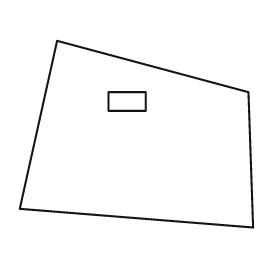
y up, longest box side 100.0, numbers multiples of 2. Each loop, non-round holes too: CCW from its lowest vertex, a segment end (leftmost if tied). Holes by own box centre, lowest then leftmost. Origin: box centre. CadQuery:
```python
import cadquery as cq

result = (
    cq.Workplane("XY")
    .moveTo(50.0, -40.0)
    .lineTo(48.0, 18.0)
    .lineTo(-34.0, 40.0)
    .lineTo(-50.0, -32.0)
    .close()
    .moveTo(-12.0, 10.0)
    .lineTo(4.0, 10.0)
    .lineTo(4.0, 18.0)
    .lineTo(-12.0, 18.0)
    .close()
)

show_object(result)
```